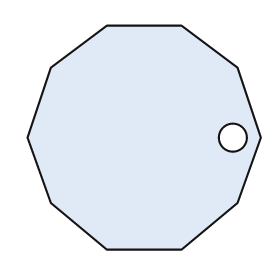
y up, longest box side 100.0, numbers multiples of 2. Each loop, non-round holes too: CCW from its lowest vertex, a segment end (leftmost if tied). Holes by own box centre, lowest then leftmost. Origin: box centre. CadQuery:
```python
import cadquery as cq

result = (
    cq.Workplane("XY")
    .moveTo(-16.0, -48.0)
    .lineTo(16.0, -48.0)
    .lineTo(40.0, -28.0)
    .lineTo(50.0, 0.0)
    .lineTo(40.0, 30.0)
    .lineTo(16.0, 48.0)
    .lineTo(-16.0, 48.0)
    .lineTo(-40.0, 30.0)
    .lineTo(-50.0, 0.0)
    .lineTo(-40.0, -28.0)
    .close()
    .moveTo(38.0, 0.0)
    .circle(6.0)
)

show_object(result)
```